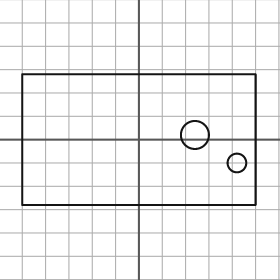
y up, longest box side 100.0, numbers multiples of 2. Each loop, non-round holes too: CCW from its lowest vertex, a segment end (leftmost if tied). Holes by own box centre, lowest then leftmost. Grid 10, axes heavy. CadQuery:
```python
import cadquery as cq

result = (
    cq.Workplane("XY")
    .moveTo(-50.0, -28.0)
    .lineTo(50.0, -28.0)
    .lineTo(50.0, 28.0)
    .lineTo(-50.0, 28.0)
    .close()
    .moveTo(42.0, -10.0)
    .circle(4.0)
    .moveTo(24.0, 2.0)
    .circle(6.0)
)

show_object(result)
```